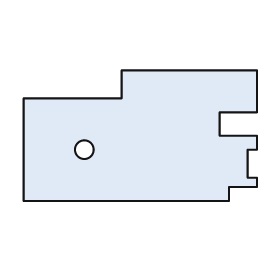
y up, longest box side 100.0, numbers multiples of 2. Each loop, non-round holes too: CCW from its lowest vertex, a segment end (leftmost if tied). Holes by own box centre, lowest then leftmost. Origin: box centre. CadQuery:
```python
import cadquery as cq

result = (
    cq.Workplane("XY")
    .moveTo(-50.0, -28.0)
    .lineTo(38.0, -28.0)
    .lineTo(38.0, -22.0)
    .lineTo(50.0, -22.0)
    .lineTo(50.0, -18.0)
    .lineTo(46.0, -18.0)
    .lineTo(46.0, -6.0)
    .lineTo(50.0, -6.0)
    .lineTo(50.0, 0.0)
    .lineTo(34.0, 0.0)
    .lineTo(34.0, 10.0)
    .lineTo(50.0, 10.0)
    .lineTo(50.0, 28.0)
    .lineTo(-8.0, 28.0)
    .lineTo(-8.0, 16.0)
    .lineTo(-50.0, 16.0)
    .close()
    .moveTo(-24.0, -6.0)
    .circle(4.0)
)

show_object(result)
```